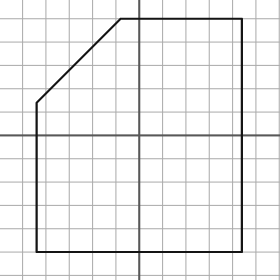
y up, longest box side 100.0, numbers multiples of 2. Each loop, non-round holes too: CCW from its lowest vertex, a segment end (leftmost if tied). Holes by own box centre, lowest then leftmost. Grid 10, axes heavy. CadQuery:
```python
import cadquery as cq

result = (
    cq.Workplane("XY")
    .moveTo(-44.0, -50.0)
    .lineTo(44.0, -50.0)
    .lineTo(44.0, 50.0)
    .lineTo(-8.0, 50.0)
    .lineTo(-44.0, 14.0)
    .close()
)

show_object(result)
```